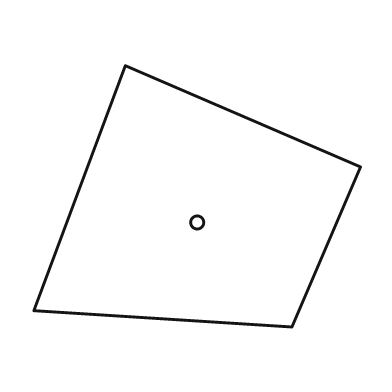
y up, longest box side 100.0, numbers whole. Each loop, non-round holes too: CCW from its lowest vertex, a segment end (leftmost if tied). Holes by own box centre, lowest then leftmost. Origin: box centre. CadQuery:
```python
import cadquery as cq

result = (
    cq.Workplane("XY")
    .moveTo(29.0, -40.0)
    .lineTo(50.0, 9.0)
    .lineTo(-22.0, 40.0)
    .lineTo(-50.0, -35.0)
    .close()
    .moveTo(0.0, -8.0)
    .circle(2.0)
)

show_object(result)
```